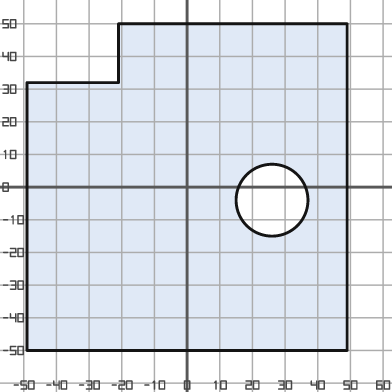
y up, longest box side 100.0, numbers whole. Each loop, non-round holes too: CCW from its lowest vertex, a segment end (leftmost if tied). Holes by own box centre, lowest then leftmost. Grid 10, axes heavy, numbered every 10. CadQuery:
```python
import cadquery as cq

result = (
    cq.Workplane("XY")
    .moveTo(-49.0, -50.0)
    .lineTo(49.0, -50.0)
    .lineTo(49.0, 50.0)
    .lineTo(-21.0, 50.0)
    .lineTo(-21.0, 32.0)
    .lineTo(-49.0, 32.0)
    .close()
    .moveTo(26.0, -4.0)
    .circle(11.0)
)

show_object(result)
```